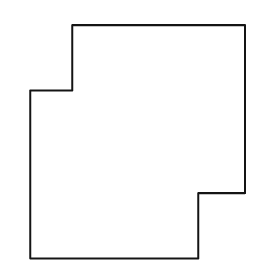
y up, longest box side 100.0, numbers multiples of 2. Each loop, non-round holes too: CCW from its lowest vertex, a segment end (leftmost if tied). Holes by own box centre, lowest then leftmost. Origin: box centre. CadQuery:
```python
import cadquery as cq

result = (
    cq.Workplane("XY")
    .moveTo(-46.0, -50.0)
    .lineTo(26.0, -50.0)
    .lineTo(26.0, -22.0)
    .lineTo(46.0, -22.0)
    .lineTo(46.0, 50.0)
    .lineTo(-28.0, 50.0)
    .lineTo(-28.0, 22.0)
    .lineTo(-46.0, 22.0)
    .close()
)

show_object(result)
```